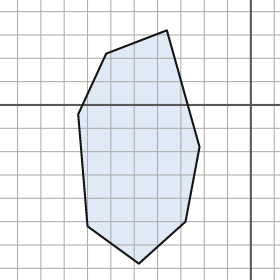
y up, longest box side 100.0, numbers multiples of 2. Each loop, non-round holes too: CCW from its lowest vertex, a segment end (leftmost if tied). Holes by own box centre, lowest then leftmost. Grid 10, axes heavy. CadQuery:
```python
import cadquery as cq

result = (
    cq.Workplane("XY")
    .moveTo(-48.0, -68.0)
    .lineTo(-28.0, -50.0)
    .lineTo(-22.0, -18.0)
    .lineTo(-36.0, 32.0)
    .lineTo(-62.0, 22.0)
    .lineTo(-74.0, -4.0)
    .lineTo(-70.0, -52.0)
    .close()
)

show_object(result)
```